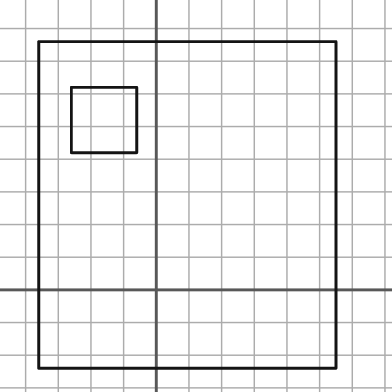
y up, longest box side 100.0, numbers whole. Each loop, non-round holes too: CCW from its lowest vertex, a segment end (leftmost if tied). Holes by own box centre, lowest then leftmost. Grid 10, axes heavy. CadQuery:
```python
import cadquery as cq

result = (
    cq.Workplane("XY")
    .moveTo(-36.0, -24.0)
    .lineTo(55.0, -24.0)
    .lineTo(55.0, 76.0)
    .lineTo(-36.0, 76.0)
    .close()
    .moveTo(-26.0, 42.0)
    .lineTo(-6.0, 42.0)
    .lineTo(-6.0, 62.0)
    .lineTo(-26.0, 62.0)
    .close()
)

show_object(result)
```